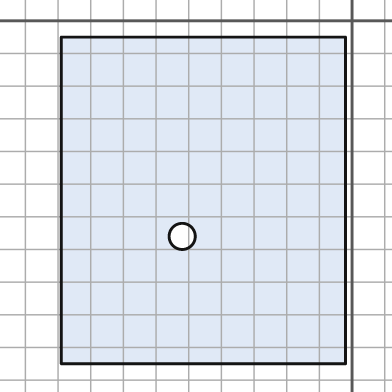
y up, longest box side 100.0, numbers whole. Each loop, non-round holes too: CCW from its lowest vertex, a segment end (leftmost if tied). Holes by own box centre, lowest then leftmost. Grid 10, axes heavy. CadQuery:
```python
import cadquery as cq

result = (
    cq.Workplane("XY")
    .moveTo(-89.0, -105.0)
    .lineTo(-2.0, -105.0)
    .lineTo(-2.0, -5.0)
    .lineTo(-89.0, -5.0)
    .close()
    .moveTo(-52.0, -66.0)
    .circle(4.0)
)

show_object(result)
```